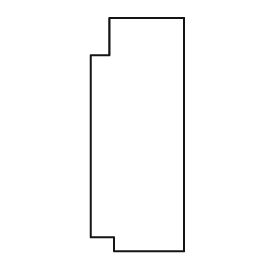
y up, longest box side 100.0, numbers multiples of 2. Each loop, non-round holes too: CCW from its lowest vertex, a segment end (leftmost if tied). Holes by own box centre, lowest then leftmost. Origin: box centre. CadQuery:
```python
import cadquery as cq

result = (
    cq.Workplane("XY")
    .moveTo(-10.0, -50.0)
    .lineTo(20.0, -50.0)
    .lineTo(20.0, 50.0)
    .lineTo(-12.0, 50.0)
    .lineTo(-12.0, 34.0)
    .lineTo(-20.0, 34.0)
    .lineTo(-20.0, -44.0)
    .lineTo(-10.0, -44.0)
    .close()
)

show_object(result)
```